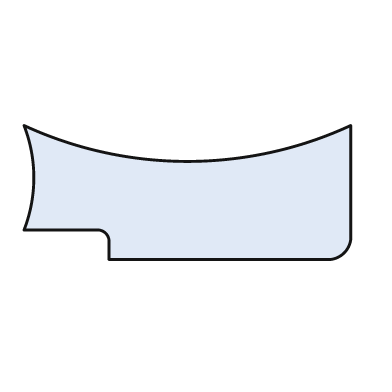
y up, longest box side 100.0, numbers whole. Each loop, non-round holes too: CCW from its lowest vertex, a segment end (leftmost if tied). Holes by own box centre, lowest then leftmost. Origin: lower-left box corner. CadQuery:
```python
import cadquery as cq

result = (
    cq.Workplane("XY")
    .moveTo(26.0, 0.0)
    .lineTo(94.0, 0.0)
    .threePointArc((98.0, 2.0), (100.0, 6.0))
    .lineTo(100.0, 41.0)
    .threePointArc((50.0, 30.0), (0.0, 41.0))
    .threePointArc((3.0, 25.0), (0.0, 9.0))
    .lineTo(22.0, 9.0)
    .threePointArc((25.0, 8.0), (26.0, 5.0))
    .close()
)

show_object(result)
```